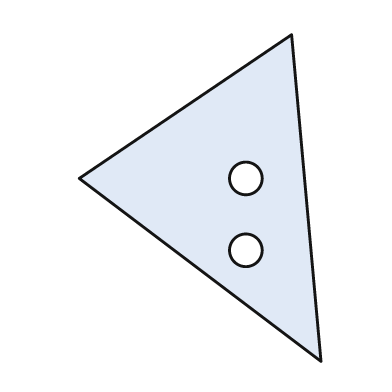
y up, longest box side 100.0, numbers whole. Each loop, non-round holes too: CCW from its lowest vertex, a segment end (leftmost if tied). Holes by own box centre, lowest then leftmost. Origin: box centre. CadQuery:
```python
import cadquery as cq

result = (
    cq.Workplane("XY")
    .moveTo(37.0, -50.0)
    .lineTo(28.0, 50.0)
    .lineTo(-37.0, 6.0)
    .close()
    .moveTo(14.0, -16.0)
    .circle(5.0)
    .moveTo(14.0, 6.0)
    .circle(5.0)
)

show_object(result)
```